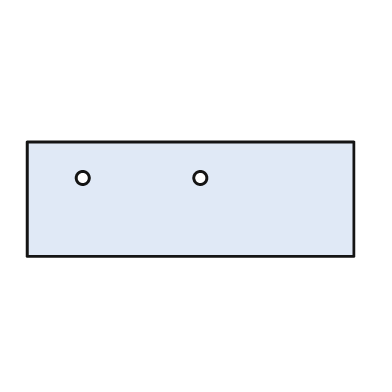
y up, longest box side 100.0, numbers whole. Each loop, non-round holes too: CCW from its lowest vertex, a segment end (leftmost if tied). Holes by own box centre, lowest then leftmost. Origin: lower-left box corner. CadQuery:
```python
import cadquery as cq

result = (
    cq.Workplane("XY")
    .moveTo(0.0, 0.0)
    .lineTo(100.0, 0.0)
    .lineTo(100.0, 35.0)
    .lineTo(0.0, 35.0)
    .close()
    .moveTo(17.0, 24.0)
    .circle(2.0)
    .moveTo(53.0, 24.0)
    .circle(2.0)
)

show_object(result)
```